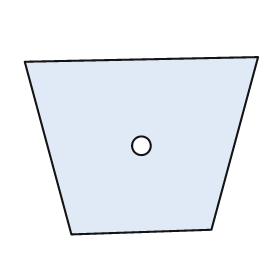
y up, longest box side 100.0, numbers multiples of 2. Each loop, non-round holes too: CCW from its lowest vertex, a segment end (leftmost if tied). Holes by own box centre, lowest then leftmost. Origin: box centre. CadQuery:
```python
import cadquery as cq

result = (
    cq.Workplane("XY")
    .moveTo(-30.0, -38.0)
    .lineTo(30.0, -36.0)
    .lineTo(50.0, 38.0)
    .lineTo(-50.0, 36.0)
    .close()
    .moveTo(0.0, 0.0)
    .circle(4.0)
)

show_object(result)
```